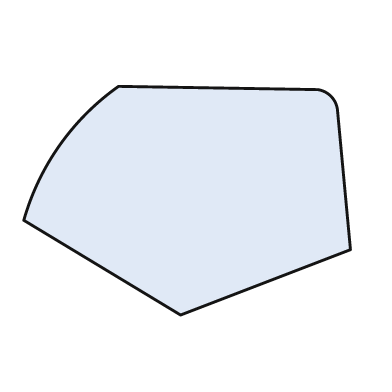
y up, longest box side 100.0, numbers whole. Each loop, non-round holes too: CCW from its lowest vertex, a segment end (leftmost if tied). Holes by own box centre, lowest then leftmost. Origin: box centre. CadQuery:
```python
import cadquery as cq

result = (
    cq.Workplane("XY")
    .moveTo(-2.0, -35.0)
    .lineTo(50.0, -15.0)
    .lineTo(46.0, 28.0)
    .threePointArc((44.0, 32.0), (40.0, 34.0))
    .lineTo(-21.0, 35.0)
    .threePointArc((-39.0, 17.0), (-50.0, -6.0))
    .close()
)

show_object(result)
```